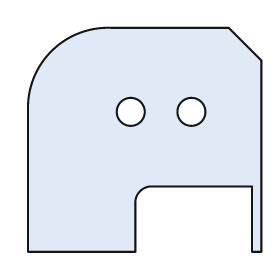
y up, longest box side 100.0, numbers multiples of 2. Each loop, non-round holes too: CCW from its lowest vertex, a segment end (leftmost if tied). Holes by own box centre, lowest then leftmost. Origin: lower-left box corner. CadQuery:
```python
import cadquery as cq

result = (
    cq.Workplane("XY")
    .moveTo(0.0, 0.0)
    .lineTo(46.0, 0.0)
    .lineTo(46.0, 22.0)
    .threePointArc((48.0, 26.0), (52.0, 28.0))
    .lineTo(96.0, 28.0)
    .lineTo(96.0, 0.0)
    .lineTo(100.0, 0.0)
    .lineTo(100.0, 82.0)
    .lineTo(86.0, 96.0)
    .lineTo(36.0, 96.0)
    .threePointArc((10.0, 86.0), (0.0, 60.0))
    .close()
    .moveTo(44.0, 60.0)
    .circle(6.0)
    .moveTo(70.0, 60.0)
    .circle(6.0)
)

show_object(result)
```